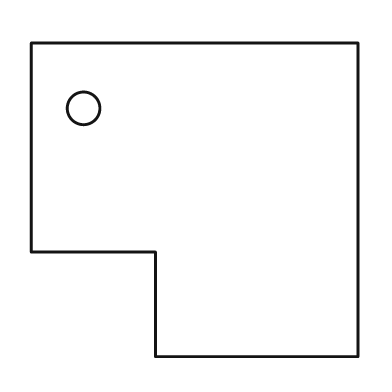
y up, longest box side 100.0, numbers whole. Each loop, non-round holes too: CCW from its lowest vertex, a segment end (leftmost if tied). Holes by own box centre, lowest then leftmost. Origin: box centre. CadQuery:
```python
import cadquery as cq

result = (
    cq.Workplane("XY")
    .moveTo(-12.0, -48.0)
    .lineTo(50.0, -48.0)
    .lineTo(50.0, 48.0)
    .lineTo(-50.0, 48.0)
    .lineTo(-50.0, -16.0)
    .lineTo(-12.0, -16.0)
    .close()
    .moveTo(-34.0, 28.0)
    .circle(5.0)
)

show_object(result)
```